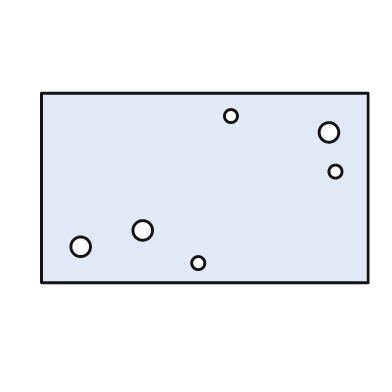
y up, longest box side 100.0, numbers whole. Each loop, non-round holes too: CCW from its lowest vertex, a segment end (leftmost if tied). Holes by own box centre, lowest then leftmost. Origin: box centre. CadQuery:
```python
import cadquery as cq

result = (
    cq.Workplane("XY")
    .moveTo(-50.0, -29.0)
    .lineTo(50.0, -29.0)
    .lineTo(50.0, 29.0)
    .lineTo(-50.0, 29.0)
    .close()
    .moveTo(-2.0, -23.0)
    .circle(2.0)
    .moveTo(-38.0, -18.0)
    .circle(3.0)
    .moveTo(-19.0, -13.0)
    .circle(3.0)
    .moveTo(40.0, 5.0)
    .circle(2.0)
    .moveTo(38.0, 17.0)
    .circle(3.0)
    .moveTo(8.0, 22.0)
    .circle(2.0)
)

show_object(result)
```